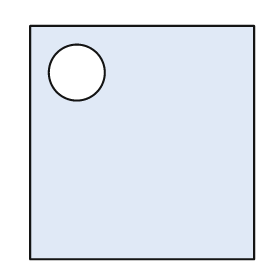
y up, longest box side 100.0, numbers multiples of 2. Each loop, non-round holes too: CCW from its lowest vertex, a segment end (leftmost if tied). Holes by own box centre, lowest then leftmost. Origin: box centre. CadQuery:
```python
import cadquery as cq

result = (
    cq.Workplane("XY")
    .moveTo(-48.0, -50.0)
    .lineTo(48.0, -50.0)
    .lineTo(48.0, 50.0)
    .lineTo(-48.0, 50.0)
    .close()
    .moveTo(-28.0, 30.0)
    .circle(12.0)
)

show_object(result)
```